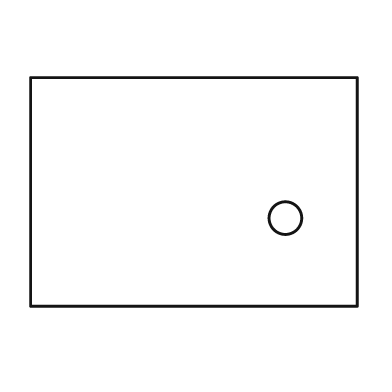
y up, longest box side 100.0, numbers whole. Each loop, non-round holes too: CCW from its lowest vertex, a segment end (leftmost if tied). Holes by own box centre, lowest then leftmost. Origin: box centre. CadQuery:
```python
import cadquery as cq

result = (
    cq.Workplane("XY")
    .moveTo(-50.0, -35.0)
    .lineTo(50.0, -35.0)
    .lineTo(50.0, 35.0)
    .lineTo(-50.0, 35.0)
    .close()
    .moveTo(28.0, -8.0)
    .circle(5.0)
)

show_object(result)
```